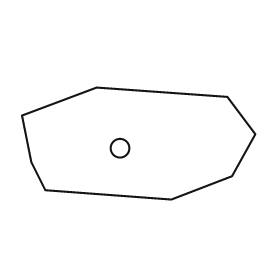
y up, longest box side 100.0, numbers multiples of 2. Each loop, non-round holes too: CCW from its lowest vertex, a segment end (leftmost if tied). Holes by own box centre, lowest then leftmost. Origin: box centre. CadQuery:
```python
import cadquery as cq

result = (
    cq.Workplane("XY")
    .moveTo(14.0, -24.0)
    .lineTo(40.0, -14.0)
    .lineTo(50.0, 4.0)
    .lineTo(38.0, 20.0)
    .lineTo(-18.0, 24.0)
    .lineTo(-50.0, 12.0)
    .lineTo(-46.0, -8.0)
    .lineTo(-40.0, -20.0)
    .close()
    .moveTo(-8.0, -2.0)
    .circle(4.0)
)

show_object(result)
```